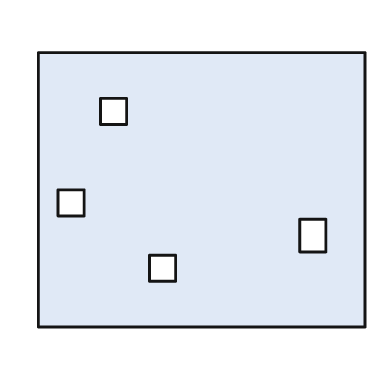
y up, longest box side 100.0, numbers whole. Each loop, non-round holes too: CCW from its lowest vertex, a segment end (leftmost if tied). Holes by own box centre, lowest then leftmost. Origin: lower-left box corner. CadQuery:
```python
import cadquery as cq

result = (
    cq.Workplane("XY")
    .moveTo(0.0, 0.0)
    .lineTo(100.0, 0.0)
    .lineTo(100.0, 84.0)
    .lineTo(0.0, 84.0)
    .close()
    .moveTo(34.0, 14.0)
    .lineTo(42.0, 14.0)
    .lineTo(42.0, 22.0)
    .lineTo(34.0, 22.0)
    .close()
    .moveTo(80.0, 23.0)
    .lineTo(88.0, 23.0)
    .lineTo(88.0, 33.0)
    .lineTo(80.0, 33.0)
    .close()
    .moveTo(6.0, 34.0)
    .lineTo(14.0, 34.0)
    .lineTo(14.0, 42.0)
    .lineTo(6.0, 42.0)
    .close()
    .moveTo(19.0, 62.0)
    .lineTo(27.0, 62.0)
    .lineTo(27.0, 70.0)
    .lineTo(19.0, 70.0)
    .close()
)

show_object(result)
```